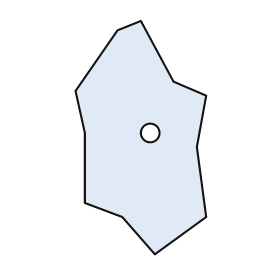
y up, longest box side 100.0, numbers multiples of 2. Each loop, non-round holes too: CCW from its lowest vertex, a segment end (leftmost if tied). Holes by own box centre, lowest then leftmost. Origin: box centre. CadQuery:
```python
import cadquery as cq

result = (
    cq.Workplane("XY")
    .moveTo(6.0, -50.0)
    .lineTo(28.0, -34.0)
    .lineTo(24.0, -4.0)
    .lineTo(28.0, 18.0)
    .lineTo(14.0, 24.0)
    .lineTo(0.0, 50.0)
    .lineTo(-10.0, 46.0)
    .lineTo(-28.0, 20.0)
    .lineTo(-24.0, 2.0)
    .lineTo(-24.0, -28.0)
    .lineTo(-8.0, -34.0)
    .close()
    .moveTo(4.0, 2.0)
    .circle(4.0)
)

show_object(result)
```